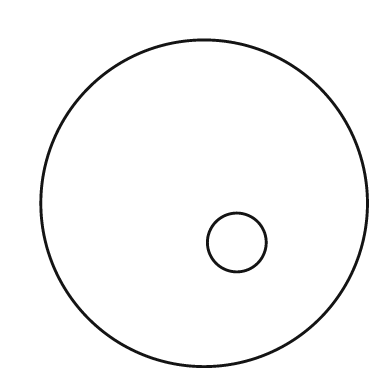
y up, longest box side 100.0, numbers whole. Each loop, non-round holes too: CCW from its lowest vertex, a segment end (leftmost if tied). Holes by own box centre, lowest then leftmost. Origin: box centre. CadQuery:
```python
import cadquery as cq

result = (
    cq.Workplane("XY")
    .moveTo(0.0, 0.0)
    .circle(50.0)
    .moveTo(10.0, -12.0)
    .circle(9.0)
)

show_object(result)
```